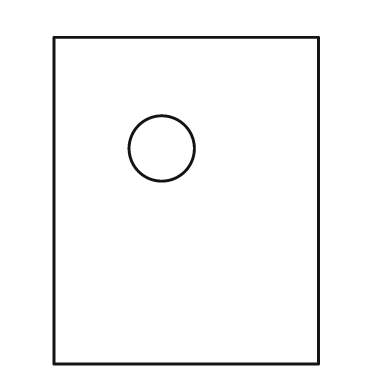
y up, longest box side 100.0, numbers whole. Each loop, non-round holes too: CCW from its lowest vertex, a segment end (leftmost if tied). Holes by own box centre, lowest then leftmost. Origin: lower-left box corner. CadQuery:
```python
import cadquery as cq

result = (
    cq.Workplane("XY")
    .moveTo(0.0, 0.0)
    .lineTo(81.0, 0.0)
    .lineTo(81.0, 100.0)
    .lineTo(0.0, 100.0)
    .close()
    .moveTo(33.0, 66.0)
    .circle(10.0)
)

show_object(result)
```